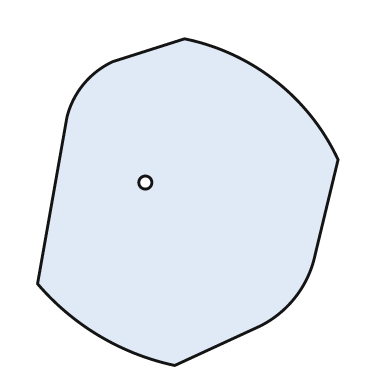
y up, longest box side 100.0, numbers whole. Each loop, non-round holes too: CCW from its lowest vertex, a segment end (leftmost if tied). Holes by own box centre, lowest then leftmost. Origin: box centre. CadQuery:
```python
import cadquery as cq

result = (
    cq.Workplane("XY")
    .moveTo(-4.0, -50.0)
    .lineTo(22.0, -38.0)
    .threePointArc((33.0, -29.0), (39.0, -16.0))
    .lineTo(46.0, 13.0)
    .threePointArc((27.0, 37.0), (-1.0, 50.0))
    .lineTo(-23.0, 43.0)
    .threePointArc((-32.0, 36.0), (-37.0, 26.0))
    .lineTo(-46.0, -25.0)
    .threePointArc((-27.0, -41.0), (-4.0, -50.0))
    .close()
    .moveTo(-13.0, 6.0)
    .circle(2.0)
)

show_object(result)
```